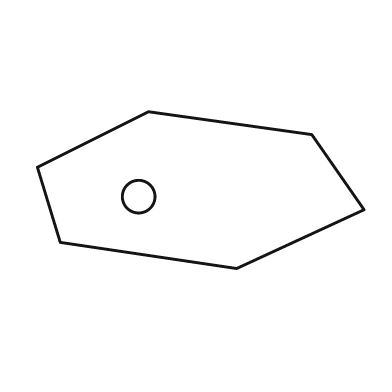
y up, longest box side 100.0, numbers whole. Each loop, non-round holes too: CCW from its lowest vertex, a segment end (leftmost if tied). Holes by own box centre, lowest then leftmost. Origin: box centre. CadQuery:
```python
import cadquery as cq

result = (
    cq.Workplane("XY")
    .moveTo(11.0, -24.0)
    .lineTo(50.0, -6.0)
    .lineTo(34.0, 17.0)
    .lineTo(-16.0, 24.0)
    .lineTo(-50.0, 7.0)
    .lineTo(-43.0, -16.0)
    .close()
    .moveTo(-19.0, -2.0)
    .circle(5.0)
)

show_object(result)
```